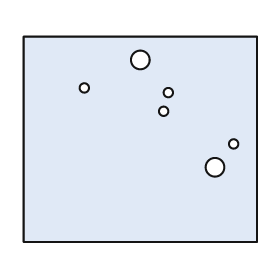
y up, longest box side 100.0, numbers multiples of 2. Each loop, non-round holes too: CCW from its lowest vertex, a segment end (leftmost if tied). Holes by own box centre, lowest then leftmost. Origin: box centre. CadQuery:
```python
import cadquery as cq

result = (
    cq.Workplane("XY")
    .moveTo(-50.0, -44.0)
    .lineTo(50.0, -44.0)
    .lineTo(50.0, 44.0)
    .lineTo(-50.0, 44.0)
    .close()
    .moveTo(32.0, -12.0)
    .circle(4.0)
    .moveTo(40.0, -2.0)
    .circle(2.0)
    .moveTo(10.0, 12.0)
    .circle(2.0)
    .moveTo(12.0, 20.0)
    .circle(2.0)
    .moveTo(-24.0, 22.0)
    .circle(2.0)
    .moveTo(0.0, 34.0)
    .circle(4.0)
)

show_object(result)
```